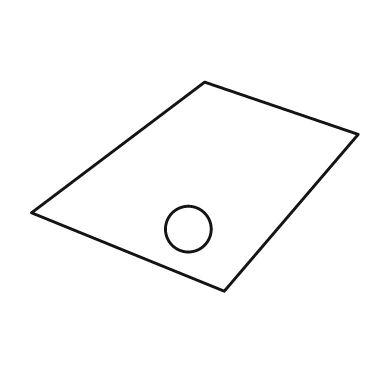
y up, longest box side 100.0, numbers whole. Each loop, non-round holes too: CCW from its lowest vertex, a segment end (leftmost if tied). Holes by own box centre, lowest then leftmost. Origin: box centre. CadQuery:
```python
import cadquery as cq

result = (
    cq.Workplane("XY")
    .moveTo(9.0, -32.0)
    .lineTo(50.0, 16.0)
    .lineTo(3.0, 32.0)
    .lineTo(-50.0, -8.0)
    .close()
    .moveTo(-2.0, -13.0)
    .circle(7.0)
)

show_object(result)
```